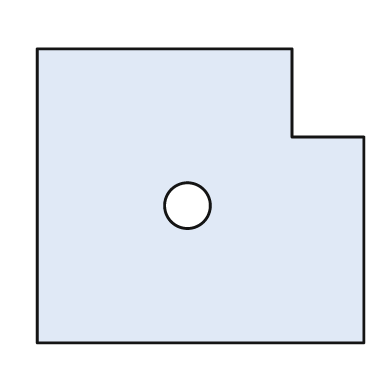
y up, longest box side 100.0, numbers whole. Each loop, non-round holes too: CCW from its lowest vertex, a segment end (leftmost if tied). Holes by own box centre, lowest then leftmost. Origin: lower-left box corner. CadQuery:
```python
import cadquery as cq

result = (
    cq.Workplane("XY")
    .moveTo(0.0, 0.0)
    .lineTo(100.0, 0.0)
    .lineTo(100.0, 63.0)
    .lineTo(78.0, 63.0)
    .lineTo(78.0, 90.0)
    .lineTo(0.0, 90.0)
    .close()
    .moveTo(46.0, 42.0)
    .circle(7.0)
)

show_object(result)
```